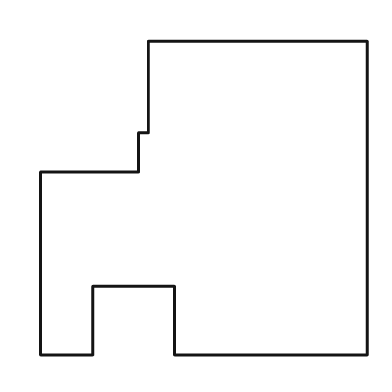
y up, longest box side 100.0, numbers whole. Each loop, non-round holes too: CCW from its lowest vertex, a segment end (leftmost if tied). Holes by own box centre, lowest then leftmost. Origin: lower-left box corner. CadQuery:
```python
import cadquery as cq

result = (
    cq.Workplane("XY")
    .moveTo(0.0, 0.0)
    .lineTo(16.0, 0.0)
    .lineTo(16.0, 21.0)
    .lineTo(41.0, 21.0)
    .lineTo(41.0, 0.0)
    .lineTo(100.0, 0.0)
    .lineTo(100.0, 96.0)
    .lineTo(33.0, 96.0)
    .lineTo(33.0, 68.0)
    .lineTo(30.0, 68.0)
    .lineTo(30.0, 56.0)
    .lineTo(0.0, 56.0)
    .close()
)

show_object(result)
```